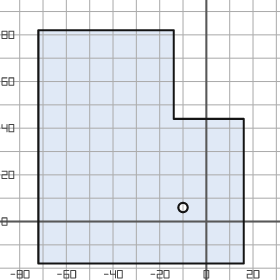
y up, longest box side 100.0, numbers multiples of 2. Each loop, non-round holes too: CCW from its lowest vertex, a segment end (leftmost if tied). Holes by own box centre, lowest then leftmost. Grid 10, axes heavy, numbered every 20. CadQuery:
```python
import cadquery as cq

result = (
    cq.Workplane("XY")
    .moveTo(-72.0, -18.0)
    .lineTo(16.0, -18.0)
    .lineTo(16.0, 44.0)
    .lineTo(-14.0, 44.0)
    .lineTo(-14.0, 82.0)
    .lineTo(-72.0, 82.0)
    .close()
    .moveTo(-10.0, 6.0)
    .circle(2.0)
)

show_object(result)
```